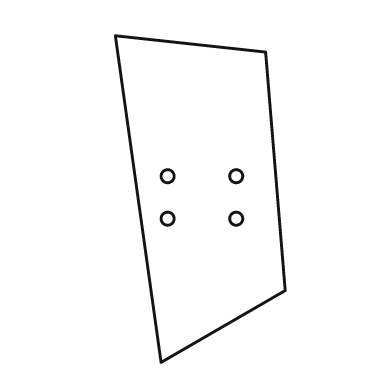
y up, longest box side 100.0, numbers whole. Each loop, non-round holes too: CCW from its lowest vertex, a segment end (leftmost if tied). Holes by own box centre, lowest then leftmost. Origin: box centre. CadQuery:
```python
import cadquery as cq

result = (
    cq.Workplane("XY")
    .moveTo(-12.0, -50.0)
    .lineTo(26.0, -28.0)
    .lineTo(20.0, 45.0)
    .lineTo(-26.0, 50.0)
    .close()
    .moveTo(-10.0, -6.0)
    .circle(2.0)
    .moveTo(11.0, -6.0)
    .circle(2.0)
    .moveTo(-10.0, 7.0)
    .circle(2.0)
    .moveTo(11.0, 7.0)
    .circle(2.0)
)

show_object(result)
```